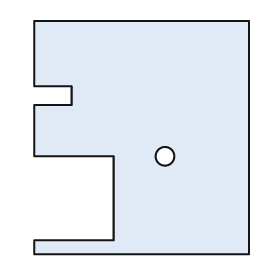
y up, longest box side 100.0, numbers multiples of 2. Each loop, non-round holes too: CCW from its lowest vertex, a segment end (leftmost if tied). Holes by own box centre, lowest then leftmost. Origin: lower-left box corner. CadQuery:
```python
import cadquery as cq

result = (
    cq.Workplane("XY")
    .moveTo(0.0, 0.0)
    .lineTo(92.0, 0.0)
    .lineTo(92.0, 100.0)
    .lineTo(0.0, 100.0)
    .lineTo(0.0, 72.0)
    .lineTo(16.0, 72.0)
    .lineTo(16.0, 64.0)
    .lineTo(0.0, 64.0)
    .lineTo(0.0, 42.0)
    .lineTo(34.0, 42.0)
    .lineTo(34.0, 6.0)
    .lineTo(0.0, 6.0)
    .close()
    .moveTo(56.0, 42.0)
    .circle(4.0)
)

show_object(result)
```